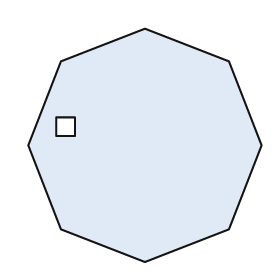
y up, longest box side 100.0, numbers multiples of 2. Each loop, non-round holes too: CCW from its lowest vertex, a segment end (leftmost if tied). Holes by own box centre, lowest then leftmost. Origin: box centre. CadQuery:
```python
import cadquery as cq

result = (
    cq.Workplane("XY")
    .moveTo(0.0, -50.0)
    .lineTo(36.0, -36.0)
    .lineTo(50.0, 0.0)
    .lineTo(36.0, 36.0)
    .lineTo(0.0, 50.0)
    .lineTo(-36.0, 36.0)
    .lineTo(-50.0, 0.0)
    .lineTo(-36.0, -36.0)
    .close()
    .moveTo(-38.0, 4.0)
    .lineTo(-30.0, 4.0)
    .lineTo(-30.0, 12.0)
    .lineTo(-38.0, 12.0)
    .close()
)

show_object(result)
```